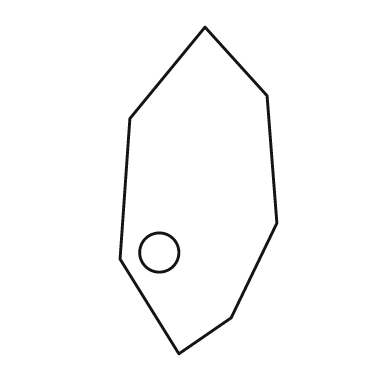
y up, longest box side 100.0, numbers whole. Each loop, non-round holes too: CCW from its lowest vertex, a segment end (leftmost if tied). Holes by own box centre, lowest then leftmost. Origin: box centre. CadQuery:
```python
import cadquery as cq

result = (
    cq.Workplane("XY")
    .moveTo(-6.0, -50.0)
    .lineTo(10.0, -39.0)
    .lineTo(24.0, -10.0)
    .lineTo(21.0, 29.0)
    .lineTo(2.0, 50.0)
    .lineTo(-21.0, 22.0)
    .lineTo(-24.0, -21.0)
    .close()
    .moveTo(-12.0, -19.0)
    .circle(6.0)
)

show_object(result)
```